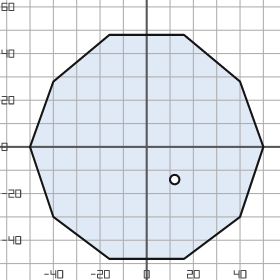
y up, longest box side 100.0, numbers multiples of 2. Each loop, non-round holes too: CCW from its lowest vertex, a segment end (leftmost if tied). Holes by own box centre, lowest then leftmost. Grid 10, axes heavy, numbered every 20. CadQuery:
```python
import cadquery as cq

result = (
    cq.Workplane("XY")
    .moveTo(-16.0, -48.0)
    .lineTo(16.0, -48.0)
    .lineTo(40.0, -30.0)
    .lineTo(50.0, 0.0)
    .lineTo(40.0, 28.0)
    .lineTo(16.0, 48.0)
    .lineTo(-16.0, 48.0)
    .lineTo(-40.0, 28.0)
    .lineTo(-50.0, 0.0)
    .lineTo(-40.0, -30.0)
    .close()
    .moveTo(12.0, -14.0)
    .circle(2.0)
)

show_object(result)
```